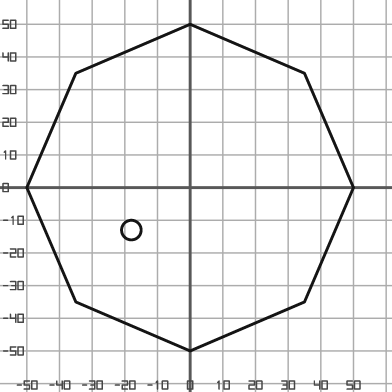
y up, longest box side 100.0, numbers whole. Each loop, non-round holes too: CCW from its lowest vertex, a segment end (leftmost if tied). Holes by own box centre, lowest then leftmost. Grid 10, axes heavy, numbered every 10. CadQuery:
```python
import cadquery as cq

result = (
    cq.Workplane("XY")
    .moveTo(0.0, -50.0)
    .lineTo(35.0, -35.0)
    .lineTo(50.0, 0.0)
    .lineTo(35.0, 35.0)
    .lineTo(0.0, 50.0)
    .lineTo(-35.0, 35.0)
    .lineTo(-50.0, 0.0)
    .lineTo(-35.0, -35.0)
    .close()
    .moveTo(-18.0, -13.0)
    .circle(3.0)
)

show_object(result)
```